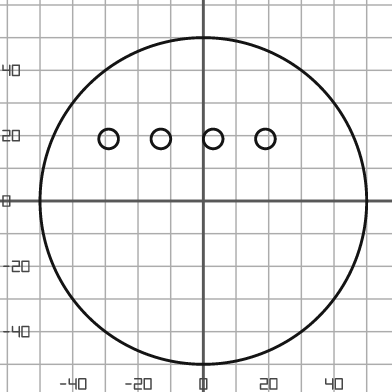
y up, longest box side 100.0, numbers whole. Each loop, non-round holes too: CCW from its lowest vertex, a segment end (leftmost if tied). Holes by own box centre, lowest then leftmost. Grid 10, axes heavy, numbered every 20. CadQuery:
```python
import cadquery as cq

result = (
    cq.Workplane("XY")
    .moveTo(0.0, 0.0)
    .circle(50.0)
    .moveTo(-29.0, 19.0)
    .circle(3.0)
    .moveTo(-13.0, 19.0)
    .circle(3.0)
    .moveTo(3.0, 19.0)
    .circle(3.0)
    .moveTo(19.0, 19.0)
    .circle(3.0)
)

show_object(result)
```